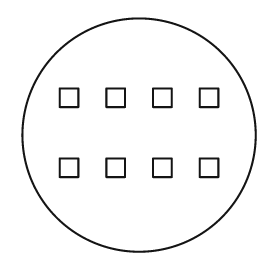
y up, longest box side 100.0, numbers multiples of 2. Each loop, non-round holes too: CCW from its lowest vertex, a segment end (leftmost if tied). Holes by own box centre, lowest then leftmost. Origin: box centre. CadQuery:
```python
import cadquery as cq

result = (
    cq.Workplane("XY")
    .moveTo(0.0, 0.0)
    .circle(50.0)
    .moveTo(-34.0, -18.0)
    .lineTo(-26.0, -18.0)
    .lineTo(-26.0, -10.0)
    .lineTo(-34.0, -10.0)
    .close()
    .moveTo(-14.0, -18.0)
    .lineTo(-6.0, -18.0)
    .lineTo(-6.0, -10.0)
    .lineTo(-14.0, -10.0)
    .close()
    .moveTo(6.0, -18.0)
    .lineTo(14.0, -18.0)
    .lineTo(14.0, -10.0)
    .lineTo(6.0, -10.0)
    .close()
    .moveTo(26.0, -18.0)
    .lineTo(34.0, -18.0)
    .lineTo(34.0, -10.0)
    .lineTo(26.0, -10.0)
    .close()
    .moveTo(-34.0, 12.0)
    .lineTo(-26.0, 12.0)
    .lineTo(-26.0, 20.0)
    .lineTo(-34.0, 20.0)
    .close()
    .moveTo(-14.0, 12.0)
    .lineTo(-6.0, 12.0)
    .lineTo(-6.0, 20.0)
    .lineTo(-14.0, 20.0)
    .close()
    .moveTo(6.0, 12.0)
    .lineTo(14.0, 12.0)
    .lineTo(14.0, 20.0)
    .lineTo(6.0, 20.0)
    .close()
    .moveTo(26.0, 12.0)
    .lineTo(34.0, 12.0)
    .lineTo(34.0, 20.0)
    .lineTo(26.0, 20.0)
    .close()
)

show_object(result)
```